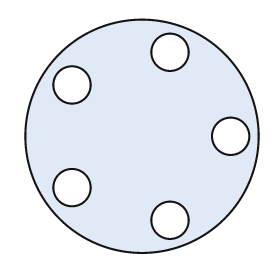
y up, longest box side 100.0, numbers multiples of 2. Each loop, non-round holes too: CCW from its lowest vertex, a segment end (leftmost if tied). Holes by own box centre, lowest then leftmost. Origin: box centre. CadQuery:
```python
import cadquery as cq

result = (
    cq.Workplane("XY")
    .moveTo(0.0, 0.0)
    .circle(50.0)
    .moveTo(12.0, -36.0)
    .circle(8.0)
    .moveTo(-30.0, -22.0)
    .circle(8.0)
    .moveTo(38.0, 0.0)
    .circle(8.0)
    .moveTo(-30.0, 22.0)
    .circle(8.0)
    .moveTo(12.0, 36.0)
    .circle(8.0)
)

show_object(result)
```